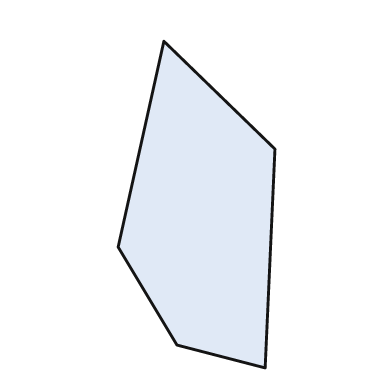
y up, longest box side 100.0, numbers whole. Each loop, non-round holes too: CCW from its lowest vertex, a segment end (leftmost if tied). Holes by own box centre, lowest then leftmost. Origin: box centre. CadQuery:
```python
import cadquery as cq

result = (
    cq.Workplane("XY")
    .moveTo(21.0, -50.0)
    .lineTo(24.0, 17.0)
    .lineTo(-10.0, 50.0)
    .lineTo(-24.0, -13.0)
    .lineTo(-6.0, -43.0)
    .close()
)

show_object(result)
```